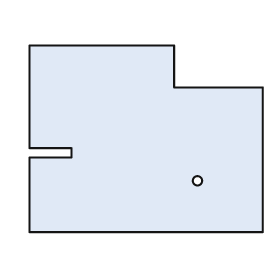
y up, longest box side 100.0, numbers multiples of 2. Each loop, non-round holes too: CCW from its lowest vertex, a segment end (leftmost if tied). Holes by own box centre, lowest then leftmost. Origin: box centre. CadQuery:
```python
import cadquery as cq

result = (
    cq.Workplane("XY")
    .moveTo(-50.0, -40.0)
    .lineTo(50.0, -40.0)
    .lineTo(50.0, 22.0)
    .lineTo(12.0, 22.0)
    .lineTo(12.0, 40.0)
    .lineTo(-50.0, 40.0)
    .lineTo(-50.0, -4.0)
    .lineTo(-32.0, -4.0)
    .lineTo(-32.0, -8.0)
    .lineTo(-50.0, -8.0)
    .close()
    .moveTo(22.0, -18.0)
    .circle(2.0)
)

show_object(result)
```